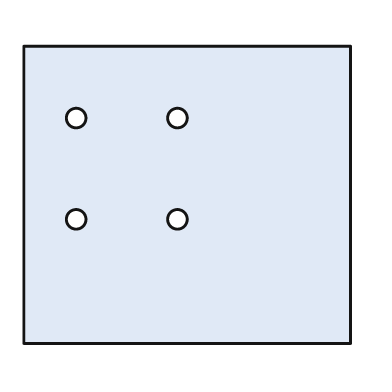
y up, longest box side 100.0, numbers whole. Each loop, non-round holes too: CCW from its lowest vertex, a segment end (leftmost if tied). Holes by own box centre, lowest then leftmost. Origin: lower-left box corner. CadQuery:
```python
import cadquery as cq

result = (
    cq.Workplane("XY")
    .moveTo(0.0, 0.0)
    .lineTo(100.0, 0.0)
    .lineTo(100.0, 91.0)
    .lineTo(0.0, 91.0)
    .close()
    .moveTo(16.0, 38.0)
    .circle(3.0)
    .moveTo(47.0, 38.0)
    .circle(3.0)
    .moveTo(16.0, 69.0)
    .circle(3.0)
    .moveTo(47.0, 69.0)
    .circle(3.0)
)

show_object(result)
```